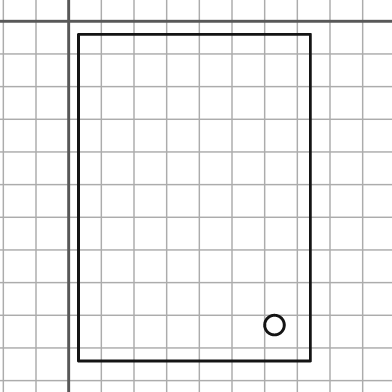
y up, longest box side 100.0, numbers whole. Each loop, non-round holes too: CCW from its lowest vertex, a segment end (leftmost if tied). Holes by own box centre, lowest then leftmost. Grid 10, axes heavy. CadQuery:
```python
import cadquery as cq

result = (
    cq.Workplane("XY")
    .moveTo(3.0, -104.0)
    .lineTo(74.0, -104.0)
    .lineTo(74.0, -4.0)
    .lineTo(3.0, -4.0)
    .close()
    .moveTo(63.0, -93.0)
    .circle(3.0)
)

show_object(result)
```